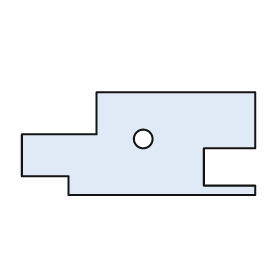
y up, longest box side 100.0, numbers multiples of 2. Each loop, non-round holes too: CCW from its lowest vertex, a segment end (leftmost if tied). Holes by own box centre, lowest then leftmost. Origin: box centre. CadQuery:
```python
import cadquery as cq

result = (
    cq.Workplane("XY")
    .moveTo(-30.0, -22.0)
    .lineTo(50.0, -22.0)
    .lineTo(50.0, -18.0)
    .lineTo(28.0, -18.0)
    .lineTo(28.0, -2.0)
    .lineTo(50.0, -2.0)
    .lineTo(50.0, 22.0)
    .lineTo(-18.0, 22.0)
    .lineTo(-18.0, 4.0)
    .lineTo(-50.0, 4.0)
    .lineTo(-50.0, -14.0)
    .lineTo(-30.0, -14.0)
    .close()
    .moveTo(2.0, 2.0)
    .circle(4.0)
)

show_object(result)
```